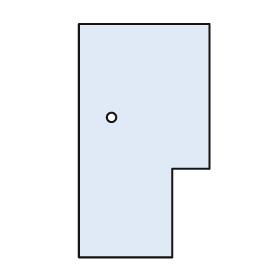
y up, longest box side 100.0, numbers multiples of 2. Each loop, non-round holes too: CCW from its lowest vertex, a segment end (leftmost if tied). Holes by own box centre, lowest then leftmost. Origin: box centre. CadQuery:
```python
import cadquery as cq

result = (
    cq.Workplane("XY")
    .moveTo(-28.0, -50.0)
    .lineTo(12.0, -50.0)
    .lineTo(12.0, -12.0)
    .lineTo(28.0, -12.0)
    .lineTo(28.0, 50.0)
    .lineTo(-28.0, 50.0)
    .close()
    .moveTo(-14.0, 10.0)
    .circle(2.0)
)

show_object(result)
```